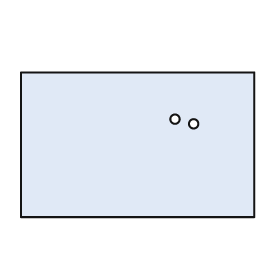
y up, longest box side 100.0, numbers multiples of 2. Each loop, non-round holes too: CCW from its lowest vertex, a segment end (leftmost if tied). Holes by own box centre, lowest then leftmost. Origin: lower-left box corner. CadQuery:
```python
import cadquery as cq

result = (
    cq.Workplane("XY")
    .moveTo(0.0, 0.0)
    .lineTo(100.0, 0.0)
    .lineTo(100.0, 62.0)
    .lineTo(0.0, 62.0)
    .close()
    .moveTo(74.0, 40.0)
    .circle(2.0)
    .moveTo(66.0, 42.0)
    .circle(2.0)
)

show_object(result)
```